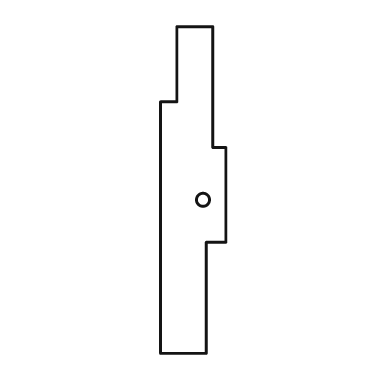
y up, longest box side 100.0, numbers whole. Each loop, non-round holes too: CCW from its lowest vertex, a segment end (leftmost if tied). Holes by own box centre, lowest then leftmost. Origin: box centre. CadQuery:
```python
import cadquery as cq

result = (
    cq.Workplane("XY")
    .moveTo(-10.0, -50.0)
    .lineTo(4.0, -50.0)
    .lineTo(4.0, -16.0)
    .lineTo(10.0, -16.0)
    .lineTo(10.0, 13.0)
    .lineTo(6.0, 13.0)
    .lineTo(6.0, 50.0)
    .lineTo(-5.0, 50.0)
    .lineTo(-5.0, 27.0)
    .lineTo(-10.0, 27.0)
    .close()
    .moveTo(3.0, -3.0)
    .circle(2.0)
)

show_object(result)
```